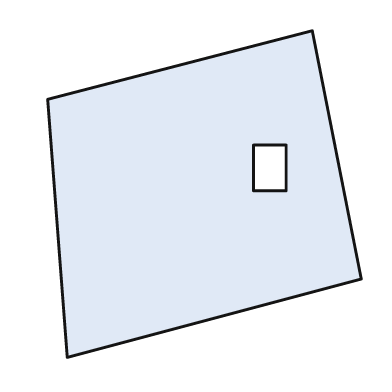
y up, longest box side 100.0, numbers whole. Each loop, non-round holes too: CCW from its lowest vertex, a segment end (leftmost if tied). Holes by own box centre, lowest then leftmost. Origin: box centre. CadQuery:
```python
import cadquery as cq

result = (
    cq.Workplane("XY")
    .moveTo(-42.0, -50.0)
    .lineTo(48.0, -26.0)
    .lineTo(33.0, 50.0)
    .lineTo(-48.0, 29.0)
    .close()
    .moveTo(15.0, 1.0)
    .lineTo(25.0, 1.0)
    .lineTo(25.0, 15.0)
    .lineTo(15.0, 15.0)
    .close()
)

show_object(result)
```